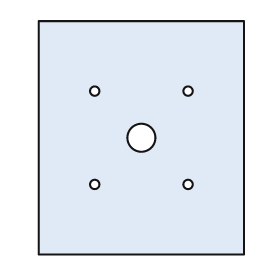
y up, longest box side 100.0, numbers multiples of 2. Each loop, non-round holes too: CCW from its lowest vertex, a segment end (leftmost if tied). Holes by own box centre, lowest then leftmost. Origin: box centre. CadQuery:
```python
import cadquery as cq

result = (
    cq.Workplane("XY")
    .moveTo(-44.0, -50.0)
    .lineTo(44.0, -50.0)
    .lineTo(44.0, 50.0)
    .lineTo(-44.0, 50.0)
    .close()
    .moveTo(-20.0, -20.0)
    .circle(2.0)
    .moveTo(20.0, -20.0)
    .circle(2.0)
    .moveTo(0.0, 0.0)
    .circle(6.0)
    .moveTo(-20.0, 20.0)
    .circle(2.0)
    .moveTo(20.0, 20.0)
    .circle(2.0)
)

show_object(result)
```